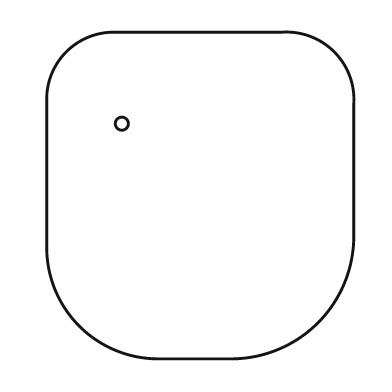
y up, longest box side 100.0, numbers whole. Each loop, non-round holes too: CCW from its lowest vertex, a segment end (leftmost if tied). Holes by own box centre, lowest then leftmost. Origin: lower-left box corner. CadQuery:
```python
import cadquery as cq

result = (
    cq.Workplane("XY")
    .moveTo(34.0, 0.0)
    .lineTo(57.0, 0.0)
    .threePointArc((83.0, 11.0), (94.0, 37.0))
    .lineTo(94.0, 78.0)
    .threePointArc((88.0, 94.0), (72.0, 100.0))
    .lineTo(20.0, 100.0)
    .threePointArc((6.0, 94.0), (0.0, 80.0))
    .lineTo(0.0, 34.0)
    .threePointArc((10.0, 10.0), (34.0, 0.0))
    .close()
    .moveTo(23.0, 72.0)
    .circle(2.0)
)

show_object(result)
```